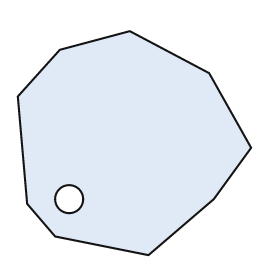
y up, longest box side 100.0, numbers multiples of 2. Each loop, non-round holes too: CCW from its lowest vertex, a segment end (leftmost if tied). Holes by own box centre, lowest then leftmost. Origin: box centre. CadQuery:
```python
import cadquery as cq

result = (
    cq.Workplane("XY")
    .moveTo(6.0, -48.0)
    .lineTo(34.0, -24.0)
    .lineTo(50.0, -2.0)
    .lineTo(32.0, 30.0)
    .lineTo(-2.0, 48.0)
    .lineTo(-32.0, 40.0)
    .lineTo(-50.0, 20.0)
    .lineTo(-46.0, -26.0)
    .lineTo(-34.0, -40.0)
    .close()
    .moveTo(-28.0, -24.0)
    .circle(6.0)
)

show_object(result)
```